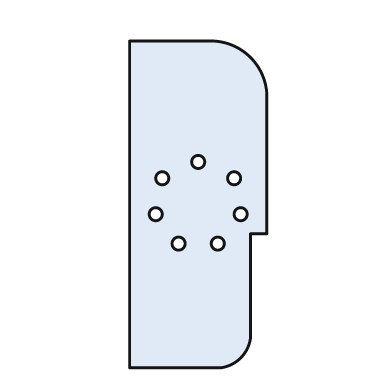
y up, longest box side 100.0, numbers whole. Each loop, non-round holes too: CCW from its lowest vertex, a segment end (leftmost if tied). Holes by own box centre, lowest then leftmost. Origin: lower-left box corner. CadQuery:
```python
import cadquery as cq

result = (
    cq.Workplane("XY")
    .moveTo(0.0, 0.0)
    .lineTo(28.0, 0.0)
    .threePointArc((34.0, 3.0), (37.0, 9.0))
    .lineTo(37.0, 41.0)
    .lineTo(42.0, 41.0)
    .lineTo(42.0, 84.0)
    .threePointArc((37.0, 95.0), (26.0, 100.0))
    .lineTo(0.0, 100.0)
    .close()
    .moveTo(15.0, 38.0)
    .circle(2.0)
    .moveTo(27.0, 38.0)
    .circle(2.0)
    .moveTo(8.0, 47.0)
    .circle(2.0)
    .moveTo(34.0, 47.0)
    .circle(2.0)
    .moveTo(10.0, 58.0)
    .circle(2.0)
    .moveTo(32.0, 58.0)
    .circle(2.0)
    .moveTo(21.0, 63.0)
    .circle(2.0)
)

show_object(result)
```